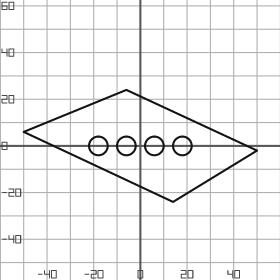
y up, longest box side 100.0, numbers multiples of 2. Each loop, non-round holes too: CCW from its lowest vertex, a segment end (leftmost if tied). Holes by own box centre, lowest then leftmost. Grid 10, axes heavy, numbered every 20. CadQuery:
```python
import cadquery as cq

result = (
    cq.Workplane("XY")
    .moveTo(14.0, -24.0)
    .lineTo(50.0, -2.0)
    .lineTo(-6.0, 24.0)
    .lineTo(-50.0, 6.0)
    .close()
    .moveTo(-18.0, 0.0)
    .circle(4.0)
    .moveTo(-6.0, 0.0)
    .circle(4.0)
    .moveTo(6.0, 0.0)
    .circle(4.0)
    .moveTo(18.0, 0.0)
    .circle(4.0)
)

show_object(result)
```